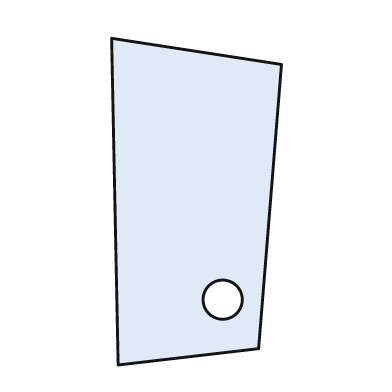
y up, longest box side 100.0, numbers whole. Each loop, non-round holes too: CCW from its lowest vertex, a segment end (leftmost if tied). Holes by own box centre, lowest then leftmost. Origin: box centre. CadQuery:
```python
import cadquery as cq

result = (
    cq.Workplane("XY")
    .moveTo(-24.0, -50.0)
    .lineTo(19.0, -45.0)
    .lineTo(26.0, 42.0)
    .lineTo(-26.0, 50.0)
    .close()
    .moveTo(8.0, -30.0)
    .circle(6.0)
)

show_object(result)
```